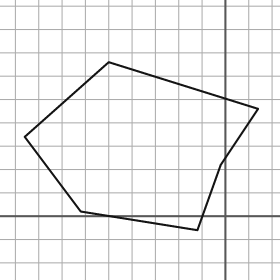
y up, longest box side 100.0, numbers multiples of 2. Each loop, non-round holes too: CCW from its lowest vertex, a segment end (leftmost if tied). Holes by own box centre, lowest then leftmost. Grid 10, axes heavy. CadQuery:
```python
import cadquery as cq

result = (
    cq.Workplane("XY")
    .moveTo(-12.0, -6.0)
    .lineTo(-2.0, 22.0)
    .lineTo(14.0, 46.0)
    .lineTo(-50.0, 66.0)
    .lineTo(-86.0, 34.0)
    .lineTo(-62.0, 2.0)
    .close()
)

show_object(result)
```